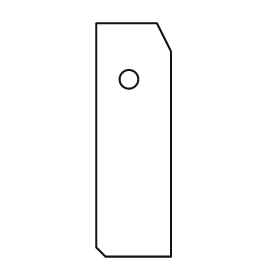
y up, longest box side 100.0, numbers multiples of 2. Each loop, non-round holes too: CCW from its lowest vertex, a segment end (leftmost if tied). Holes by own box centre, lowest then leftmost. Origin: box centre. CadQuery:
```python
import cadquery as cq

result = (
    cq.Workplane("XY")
    .moveTo(-12.0, -50.0)
    .lineTo(16.0, -50.0)
    .lineTo(16.0, 38.0)
    .lineTo(10.0, 50.0)
    .lineTo(-16.0, 50.0)
    .lineTo(-16.0, -46.0)
    .close()
    .moveTo(-2.0, 26.0)
    .circle(4.0)
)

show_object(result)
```